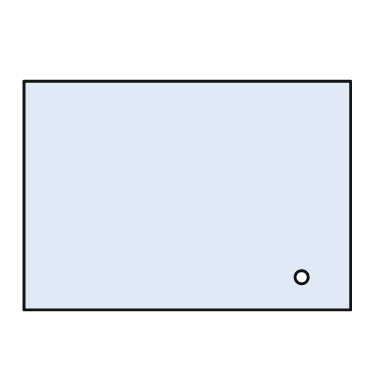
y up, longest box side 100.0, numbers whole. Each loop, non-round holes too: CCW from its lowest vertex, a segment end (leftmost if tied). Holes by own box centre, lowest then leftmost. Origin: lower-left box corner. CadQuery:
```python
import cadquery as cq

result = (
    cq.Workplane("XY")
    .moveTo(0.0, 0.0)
    .lineTo(100.0, 0.0)
    .lineTo(100.0, 70.0)
    .lineTo(0.0, 70.0)
    .close()
    .moveTo(85.0, 10.0)
    .circle(2.0)
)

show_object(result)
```